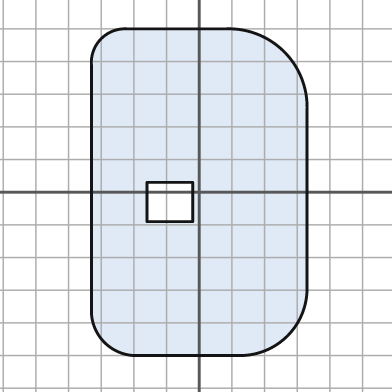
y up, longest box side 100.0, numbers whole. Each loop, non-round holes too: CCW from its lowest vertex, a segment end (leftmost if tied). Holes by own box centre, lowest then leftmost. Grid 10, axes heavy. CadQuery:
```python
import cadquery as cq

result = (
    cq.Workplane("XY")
    .moveTo(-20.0, -50.0)
    .lineTo(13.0, -50.0)
    .threePointArc((27.0, -44.0), (33.0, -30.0))
    .lineTo(33.0, 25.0)
    .threePointArc((26.0, 43.0), (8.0, 50.0))
    .lineTo(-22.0, 50.0)
    .threePointArc((-30.0, 47.0), (-33.0, 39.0))
    .lineTo(-33.0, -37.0)
    .threePointArc((-29.0, -46.0), (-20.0, -50.0))
    .close()
    .moveTo(-16.0, -9.0)
    .lineTo(-2.0, -9.0)
    .lineTo(-2.0, 3.0)
    .lineTo(-16.0, 3.0)
    .close()
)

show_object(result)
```